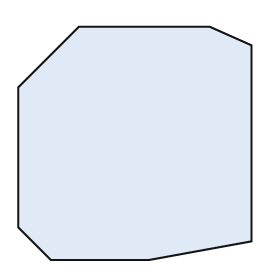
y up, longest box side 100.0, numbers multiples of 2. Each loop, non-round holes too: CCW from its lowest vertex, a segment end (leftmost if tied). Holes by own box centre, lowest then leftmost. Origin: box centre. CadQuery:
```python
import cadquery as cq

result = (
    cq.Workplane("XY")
    .moveTo(-36.0, -50.0)
    .lineTo(6.0, -50.0)
    .lineTo(50.0, -42.0)
    .lineTo(50.0, 42.0)
    .lineTo(32.0, 50.0)
    .lineTo(-24.0, 50.0)
    .lineTo(-50.0, 24.0)
    .lineTo(-50.0, -36.0)
    .close()
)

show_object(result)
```